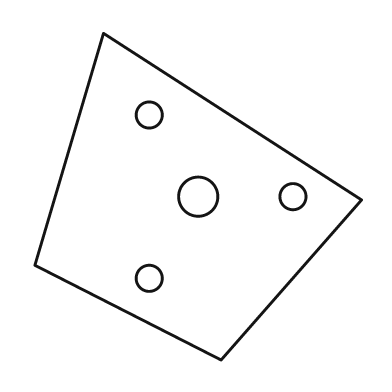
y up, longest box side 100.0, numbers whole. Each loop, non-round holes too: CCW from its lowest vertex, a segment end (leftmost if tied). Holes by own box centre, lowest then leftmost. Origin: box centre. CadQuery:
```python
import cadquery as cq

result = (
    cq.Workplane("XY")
    .moveTo(7.0, -50.0)
    .lineTo(50.0, -1.0)
    .lineTo(-29.0, 50.0)
    .lineTo(-50.0, -21.0)
    .close()
    .moveTo(-15.0, -25.0)
    .circle(4.0)
    .moveTo(0.0, 0.0)
    .circle(6.0)
    .moveTo(29.0, 0.0)
    .circle(4.0)
    .moveTo(-15.0, 25.0)
    .circle(4.0)
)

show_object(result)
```